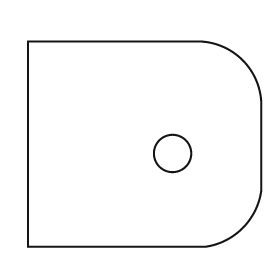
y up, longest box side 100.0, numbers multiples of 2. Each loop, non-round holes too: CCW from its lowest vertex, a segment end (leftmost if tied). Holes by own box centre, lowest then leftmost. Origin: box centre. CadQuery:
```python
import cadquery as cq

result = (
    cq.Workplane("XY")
    .moveTo(-50.0, -44.0)
    .lineTo(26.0, -44.0)
    .threePointArc((42.0, -36.0), (50.0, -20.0))
    .lineTo(50.0, 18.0)
    .threePointArc((42.0, 36.0), (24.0, 44.0))
    .lineTo(-50.0, 44.0)
    .close()
    .moveTo(12.0, -4.0)
    .circle(8.0)
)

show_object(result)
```